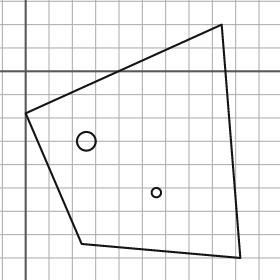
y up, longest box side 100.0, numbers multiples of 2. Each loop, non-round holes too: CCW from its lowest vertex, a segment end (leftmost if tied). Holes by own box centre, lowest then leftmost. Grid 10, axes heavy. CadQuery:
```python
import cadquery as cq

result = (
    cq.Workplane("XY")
    .moveTo(92.0, -80.0)
    .lineTo(84.0, 20.0)
    .lineTo(0.0, -18.0)
    .lineTo(24.0, -74.0)
    .close()
    .moveTo(56.0, -52.0)
    .circle(2.0)
    .moveTo(26.0, -30.0)
    .circle(4.0)
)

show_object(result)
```